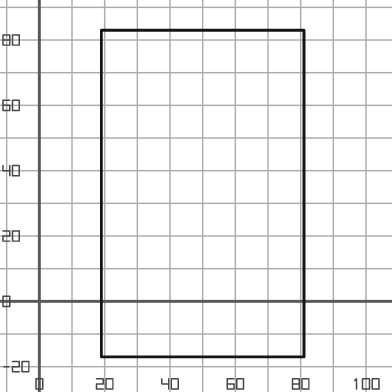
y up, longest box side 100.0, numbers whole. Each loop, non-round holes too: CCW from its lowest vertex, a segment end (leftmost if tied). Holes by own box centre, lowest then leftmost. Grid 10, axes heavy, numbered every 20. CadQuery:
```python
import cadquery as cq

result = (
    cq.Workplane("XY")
    .moveTo(19.0, -17.0)
    .lineTo(81.0, -17.0)
    .lineTo(81.0, 83.0)
    .lineTo(19.0, 83.0)
    .close()
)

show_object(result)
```